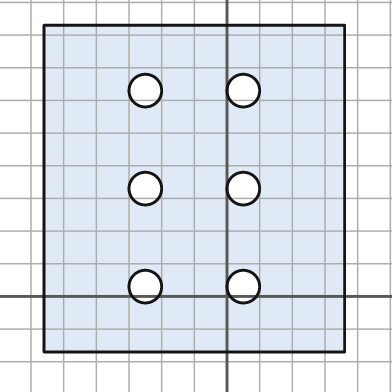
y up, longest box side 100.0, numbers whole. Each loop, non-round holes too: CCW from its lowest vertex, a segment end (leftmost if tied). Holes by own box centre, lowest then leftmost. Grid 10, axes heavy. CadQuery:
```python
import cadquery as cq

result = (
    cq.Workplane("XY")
    .moveTo(-56.0, -17.0)
    .lineTo(36.0, -17.0)
    .lineTo(36.0, 83.0)
    .lineTo(-56.0, 83.0)
    .close()
    .moveTo(-25.0, 3.0)
    .circle(5.0)
    .moveTo(5.0, 3.0)
    .circle(5.0)
    .moveTo(-25.0, 33.0)
    .circle(5.0)
    .moveTo(5.0, 33.0)
    .circle(5.0)
    .moveTo(-25.0, 63.0)
    .circle(5.0)
    .moveTo(5.0, 63.0)
    .circle(5.0)
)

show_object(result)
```